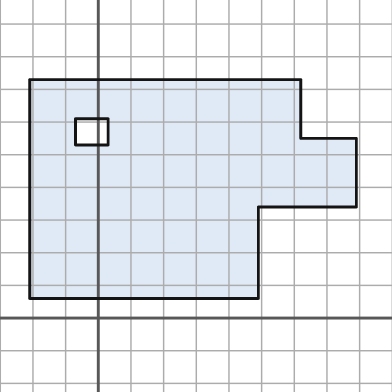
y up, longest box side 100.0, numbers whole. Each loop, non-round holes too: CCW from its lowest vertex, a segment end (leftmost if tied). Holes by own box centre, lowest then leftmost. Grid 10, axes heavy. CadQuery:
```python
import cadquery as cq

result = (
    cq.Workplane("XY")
    .moveTo(-21.0, 6.0)
    .lineTo(49.0, 6.0)
    .lineTo(49.0, 34.0)
    .lineTo(79.0, 34.0)
    .lineTo(79.0, 55.0)
    .lineTo(62.0, 55.0)
    .lineTo(62.0, 73.0)
    .lineTo(-21.0, 73.0)
    .close()
    .moveTo(-7.0, 53.0)
    .lineTo(3.0, 53.0)
    .lineTo(3.0, 61.0)
    .lineTo(-7.0, 61.0)
    .close()
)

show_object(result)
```